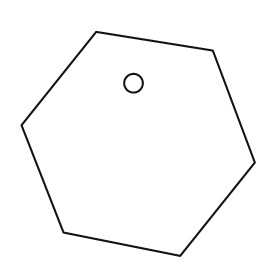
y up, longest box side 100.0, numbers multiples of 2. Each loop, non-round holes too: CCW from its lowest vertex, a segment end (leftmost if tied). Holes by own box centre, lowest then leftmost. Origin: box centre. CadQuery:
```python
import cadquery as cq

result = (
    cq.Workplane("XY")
    .moveTo(18.0, -48.0)
    .lineTo(50.0, -8.0)
    .lineTo(32.0, 40.0)
    .lineTo(-18.0, 48.0)
    .lineTo(-50.0, 8.0)
    .lineTo(-32.0, -38.0)
    .close()
    .moveTo(-2.0, 26.0)
    .circle(4.0)
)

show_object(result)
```